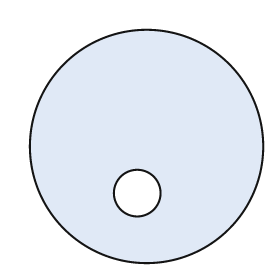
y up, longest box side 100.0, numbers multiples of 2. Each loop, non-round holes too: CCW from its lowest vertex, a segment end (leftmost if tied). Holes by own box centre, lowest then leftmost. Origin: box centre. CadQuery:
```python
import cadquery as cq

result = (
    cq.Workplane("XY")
    .moveTo(0.0, 0.0)
    .circle(50.0)
    .moveTo(-4.0, -20.0)
    .circle(10.0)
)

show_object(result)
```